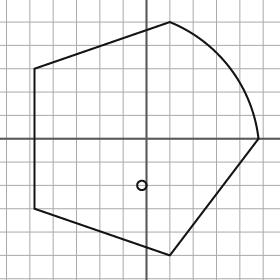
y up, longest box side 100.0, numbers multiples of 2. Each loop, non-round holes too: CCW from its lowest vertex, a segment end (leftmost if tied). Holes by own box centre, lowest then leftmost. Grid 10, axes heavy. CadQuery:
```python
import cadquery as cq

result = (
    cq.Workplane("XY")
    .moveTo(10.0, -50.0)
    .lineTo(48.0, 0.0)
    .threePointArc((36.0, 30.0), (10.0, 50.0))
    .lineTo(-48.0, 30.0)
    .lineTo(-48.0, -30.0)
    .close()
    .moveTo(-2.0, -20.0)
    .circle(2.0)
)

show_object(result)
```